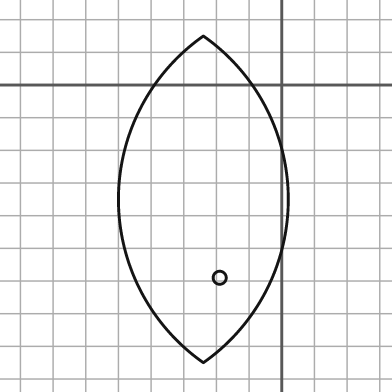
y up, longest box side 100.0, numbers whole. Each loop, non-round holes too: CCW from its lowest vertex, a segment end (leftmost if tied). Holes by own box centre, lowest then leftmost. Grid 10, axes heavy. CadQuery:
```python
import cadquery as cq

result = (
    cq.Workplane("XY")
    .moveTo(-24.0, -85.0)
    .threePointArc((2.0, -35.0), (-24.0, 15.0))
    .threePointArc((-50.0, -35.0), (-24.0, -85.0))
    .close()
    .moveTo(-19.0, -59.0)
    .circle(2.0)
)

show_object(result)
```